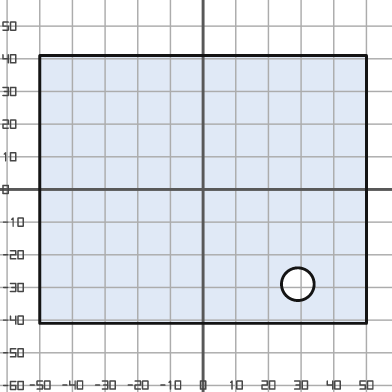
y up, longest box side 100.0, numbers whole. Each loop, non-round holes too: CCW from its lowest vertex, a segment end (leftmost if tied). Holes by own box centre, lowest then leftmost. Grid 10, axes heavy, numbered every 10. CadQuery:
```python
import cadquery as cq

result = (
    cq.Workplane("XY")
    .moveTo(-50.0, -41.0)
    .lineTo(50.0, -41.0)
    .lineTo(50.0, 41.0)
    .lineTo(-50.0, 41.0)
    .close()
    .moveTo(29.0, -29.0)
    .circle(5.0)
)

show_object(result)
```